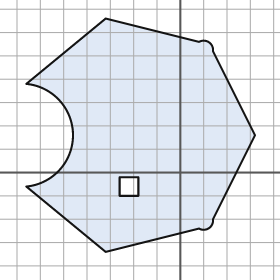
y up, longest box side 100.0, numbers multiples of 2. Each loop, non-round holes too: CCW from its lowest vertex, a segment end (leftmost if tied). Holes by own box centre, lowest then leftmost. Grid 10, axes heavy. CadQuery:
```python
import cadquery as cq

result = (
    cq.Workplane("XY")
    .moveTo(-32.0, -34.0)
    .lineTo(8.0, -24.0)
    .threePointArc((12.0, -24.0), (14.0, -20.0))
    .lineTo(32.0, 16.0)
    .lineTo(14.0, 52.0)
    .threePointArc((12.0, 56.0), (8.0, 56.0))
    .lineTo(-32.0, 66.0)
    .lineTo(-66.0, 38.0)
    .threePointArc((-46.0, 16.0), (-66.0, -6.0))
    .close()
    .moveTo(-26.0, -10.0)
    .lineTo(-18.0, -10.0)
    .lineTo(-18.0, -2.0)
    .lineTo(-26.0, -2.0)
    .close()
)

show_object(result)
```